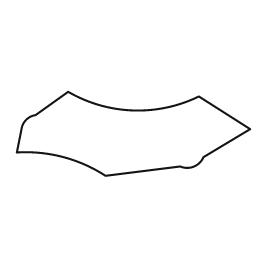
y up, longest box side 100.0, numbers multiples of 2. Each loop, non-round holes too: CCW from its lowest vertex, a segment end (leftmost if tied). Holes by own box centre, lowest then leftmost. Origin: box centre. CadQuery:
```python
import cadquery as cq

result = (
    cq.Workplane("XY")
    .moveTo(-12.0, -18.0)
    .lineTo(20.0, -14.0)
    .threePointArc((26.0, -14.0), (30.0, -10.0))
    .lineTo(50.0, 2.0)
    .lineTo(28.0, 16.0)
    .threePointArc((0.0, 10.0), (-28.0, 18.0))
    .lineTo(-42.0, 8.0)
    .threePointArc((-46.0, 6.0), (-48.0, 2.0))
    .lineTo(-50.0, -8.0)
    .threePointArc((-30.0, -10.0), (-12.0, -18.0))
    .close()
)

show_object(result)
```